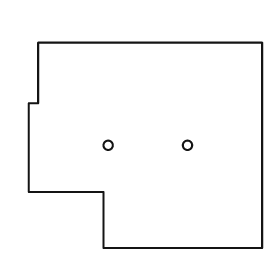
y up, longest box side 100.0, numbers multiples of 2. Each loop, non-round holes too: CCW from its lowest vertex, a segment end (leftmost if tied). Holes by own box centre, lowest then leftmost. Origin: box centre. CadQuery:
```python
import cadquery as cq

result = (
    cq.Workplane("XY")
    .moveTo(-18.0, -44.0)
    .lineTo(50.0, -44.0)
    .lineTo(50.0, 44.0)
    .lineTo(-46.0, 44.0)
    .lineTo(-46.0, 18.0)
    .lineTo(-50.0, 18.0)
    .lineTo(-50.0, -20.0)
    .lineTo(-18.0, -20.0)
    .close()
    .moveTo(-16.0, 0.0)
    .circle(2.0)
    .moveTo(18.0, 0.0)
    .circle(2.0)
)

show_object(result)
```